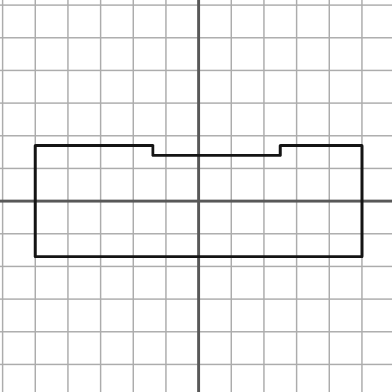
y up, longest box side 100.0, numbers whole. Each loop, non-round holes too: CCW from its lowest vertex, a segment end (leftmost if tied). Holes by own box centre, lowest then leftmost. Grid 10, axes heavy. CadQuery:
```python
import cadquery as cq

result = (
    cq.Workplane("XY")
    .moveTo(-50.0, -17.0)
    .lineTo(50.0, -17.0)
    .lineTo(50.0, 17.0)
    .lineTo(25.0, 17.0)
    .lineTo(25.0, 14.0)
    .lineTo(-14.0, 14.0)
    .lineTo(-14.0, 17.0)
    .lineTo(-50.0, 17.0)
    .close()
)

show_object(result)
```